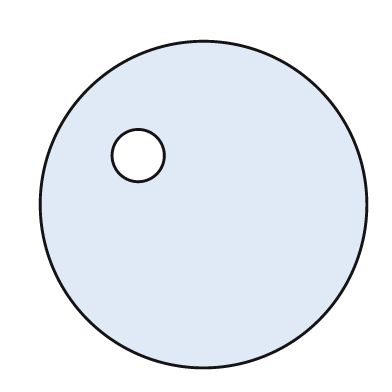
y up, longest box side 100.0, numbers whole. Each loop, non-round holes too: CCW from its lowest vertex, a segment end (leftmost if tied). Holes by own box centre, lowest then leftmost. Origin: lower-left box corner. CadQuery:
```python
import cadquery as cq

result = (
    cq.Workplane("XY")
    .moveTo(50.0, 50.0)
    .circle(50.0)
    .moveTo(30.0, 65.0)
    .circle(8.0)
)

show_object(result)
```